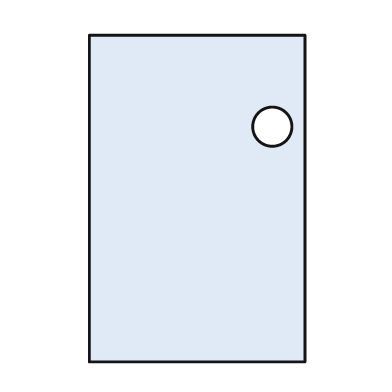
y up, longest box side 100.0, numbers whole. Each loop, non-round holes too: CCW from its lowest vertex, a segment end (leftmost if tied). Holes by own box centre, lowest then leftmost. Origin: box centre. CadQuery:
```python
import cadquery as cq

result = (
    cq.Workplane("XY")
    .moveTo(-33.0, -50.0)
    .lineTo(33.0, -50.0)
    .lineTo(33.0, 50.0)
    .lineTo(-33.0, 50.0)
    .close()
    .moveTo(23.0, 22.0)
    .circle(6.0)
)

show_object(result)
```